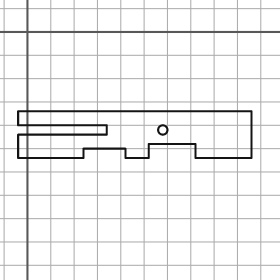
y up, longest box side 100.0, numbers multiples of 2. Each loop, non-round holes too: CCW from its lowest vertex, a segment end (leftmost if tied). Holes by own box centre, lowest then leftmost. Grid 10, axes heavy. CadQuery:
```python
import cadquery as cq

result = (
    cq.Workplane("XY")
    .moveTo(-4.0, -54.0)
    .lineTo(24.0, -54.0)
    .lineTo(24.0, -50.0)
    .lineTo(42.0, -50.0)
    .lineTo(42.0, -54.0)
    .lineTo(52.0, -54.0)
    .lineTo(52.0, -48.0)
    .lineTo(72.0, -48.0)
    .lineTo(72.0, -54.0)
    .lineTo(96.0, -54.0)
    .lineTo(96.0, -34.0)
    .lineTo(-4.0, -34.0)
    .lineTo(-4.0, -40.0)
    .lineTo(34.0, -40.0)
    .lineTo(34.0, -44.0)
    .lineTo(-4.0, -44.0)
    .close()
    .moveTo(58.0, -42.0)
    .circle(2.0)
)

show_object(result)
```